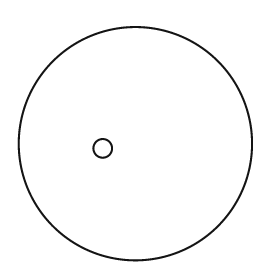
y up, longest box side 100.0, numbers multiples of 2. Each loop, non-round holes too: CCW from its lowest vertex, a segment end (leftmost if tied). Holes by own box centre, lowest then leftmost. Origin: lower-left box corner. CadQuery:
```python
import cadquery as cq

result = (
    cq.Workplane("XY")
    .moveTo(50.0, 50.0)
    .circle(50.0)
    .moveTo(36.0, 48.0)
    .circle(4.0)
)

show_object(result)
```